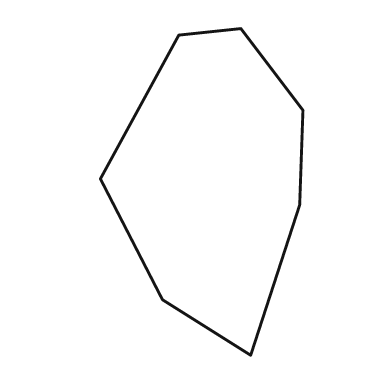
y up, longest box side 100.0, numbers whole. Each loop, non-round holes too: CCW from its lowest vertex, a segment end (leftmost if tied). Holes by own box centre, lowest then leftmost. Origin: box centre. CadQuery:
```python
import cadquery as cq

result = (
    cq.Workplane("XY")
    .moveTo(15.0, -50.0)
    .lineTo(30.0, -4.0)
    .lineTo(31.0, 25.0)
    .lineTo(12.0, 50.0)
    .lineTo(-7.0, 48.0)
    .lineTo(-31.0, 4.0)
    .lineTo(-12.0, -33.0)
    .close()
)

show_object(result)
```